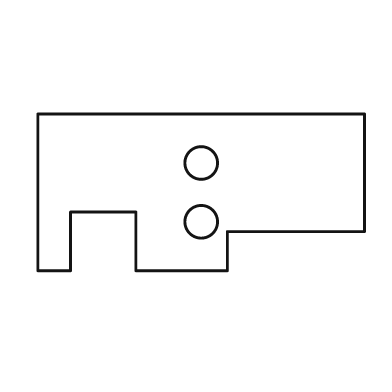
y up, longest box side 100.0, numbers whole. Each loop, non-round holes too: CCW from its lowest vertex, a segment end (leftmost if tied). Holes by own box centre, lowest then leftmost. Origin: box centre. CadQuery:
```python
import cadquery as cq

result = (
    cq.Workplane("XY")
    .moveTo(-50.0, -24.0)
    .lineTo(-40.0, -24.0)
    .lineTo(-40.0, -6.0)
    .lineTo(-20.0, -6.0)
    .lineTo(-20.0, -24.0)
    .lineTo(8.0, -24.0)
    .lineTo(8.0, -12.0)
    .lineTo(50.0, -12.0)
    .lineTo(50.0, 24.0)
    .lineTo(-50.0, 24.0)
    .close()
    .moveTo(0.0, -9.0)
    .circle(5.0)
    .moveTo(0.0, 9.0)
    .circle(5.0)
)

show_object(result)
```